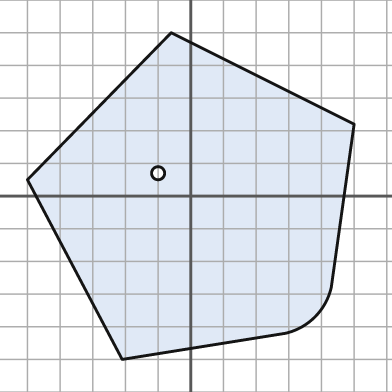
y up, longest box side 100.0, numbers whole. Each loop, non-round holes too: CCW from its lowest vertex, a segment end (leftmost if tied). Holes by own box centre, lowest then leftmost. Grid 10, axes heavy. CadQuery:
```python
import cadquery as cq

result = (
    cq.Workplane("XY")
    .moveTo(-21.0, -50.0)
    .lineTo(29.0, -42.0)
    .threePointArc((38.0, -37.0), (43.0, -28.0))
    .lineTo(50.0, 22.0)
    .lineTo(-6.0, 50.0)
    .lineTo(-50.0, 5.0)
    .close()
    .moveTo(-10.0, 7.0)
    .circle(2.0)
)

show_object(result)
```